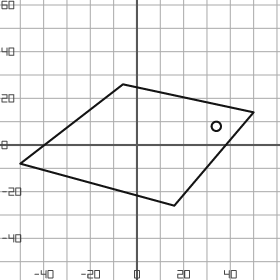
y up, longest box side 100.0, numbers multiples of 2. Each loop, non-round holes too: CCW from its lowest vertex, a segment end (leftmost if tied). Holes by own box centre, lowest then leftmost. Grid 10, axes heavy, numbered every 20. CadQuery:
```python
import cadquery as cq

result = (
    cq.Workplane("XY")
    .moveTo(16.0, -26.0)
    .lineTo(50.0, 14.0)
    .lineTo(-6.0, 26.0)
    .lineTo(-50.0, -8.0)
    .close()
    .moveTo(34.0, 8.0)
    .circle(2.0)
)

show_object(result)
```